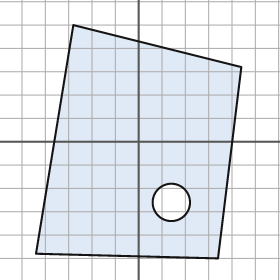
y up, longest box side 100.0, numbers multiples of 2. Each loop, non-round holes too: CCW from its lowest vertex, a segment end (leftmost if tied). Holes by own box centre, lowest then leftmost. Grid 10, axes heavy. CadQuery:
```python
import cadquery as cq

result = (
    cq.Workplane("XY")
    .moveTo(34.0, -50.0)
    .lineTo(44.0, 32.0)
    .lineTo(-28.0, 50.0)
    .lineTo(-44.0, -48.0)
    .close()
    .moveTo(14.0, -26.0)
    .circle(8.0)
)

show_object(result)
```